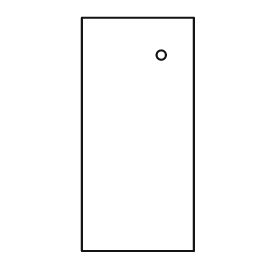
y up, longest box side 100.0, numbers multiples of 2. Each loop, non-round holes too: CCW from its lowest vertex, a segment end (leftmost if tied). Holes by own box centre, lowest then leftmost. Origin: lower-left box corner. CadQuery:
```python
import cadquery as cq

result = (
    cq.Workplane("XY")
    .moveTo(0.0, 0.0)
    .lineTo(48.0, 0.0)
    .lineTo(48.0, 100.0)
    .lineTo(0.0, 100.0)
    .close()
    .moveTo(34.0, 84.0)
    .circle(2.0)
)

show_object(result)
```